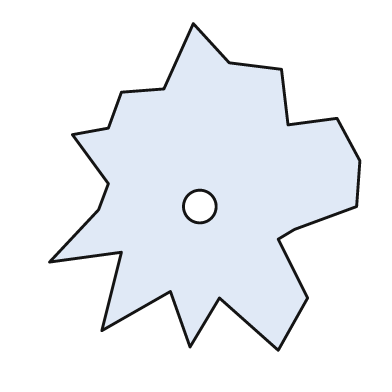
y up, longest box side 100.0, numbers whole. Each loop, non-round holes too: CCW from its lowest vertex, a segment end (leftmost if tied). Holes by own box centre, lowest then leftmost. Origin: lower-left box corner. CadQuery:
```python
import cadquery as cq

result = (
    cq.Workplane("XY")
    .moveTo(70.0, 0.0)
    .lineTo(79.0, 16.0)
    .lineTo(70.0, 34.0)
    .lineTo(75.0, 37.0)
    .lineTo(94.0, 44.0)
    .lineTo(95.0, 58.0)
    .lineTo(88.0, 71.0)
    .lineTo(73.0, 69.0)
    .lineTo(71.0, 86.0)
    .lineTo(55.0, 88.0)
    .lineTo(44.0, 100.0)
    .lineTo(35.0, 80.0)
    .lineTo(22.0, 79.0)
    .lineTo(18.0, 68.0)
    .lineTo(7.0, 66.0)
    .lineTo(18.0, 51.0)
    .lineTo(15.0, 43.0)
    .lineTo(0.0, 27.0)
    .lineTo(22.0, 30.0)
    .lineTo(16.0, 6.0)
    .lineTo(37.0, 18.0)
    .lineTo(43.0, 1.0)
    .lineTo(52.0, 16.0)
    .close()
    .moveTo(46.0, 44.0)
    .circle(5.0)
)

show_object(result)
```